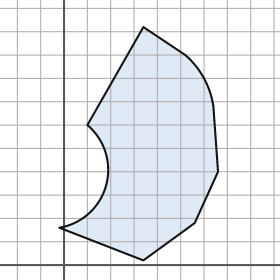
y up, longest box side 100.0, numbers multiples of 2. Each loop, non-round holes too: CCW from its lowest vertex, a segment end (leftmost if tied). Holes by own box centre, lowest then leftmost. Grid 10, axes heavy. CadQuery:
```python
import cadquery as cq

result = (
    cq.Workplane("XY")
    .moveTo(34.0, 2.0)
    .lineTo(56.0, 18.0)
    .lineTo(66.0, 40.0)
    .lineTo(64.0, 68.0)
    .threePointArc((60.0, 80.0), (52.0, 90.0))
    .lineTo(34.0, 102.0)
    .lineTo(10.0, 60.0)
    .threePointArc((18.0, 34.0), (-2.0, 16.0))
    .close()
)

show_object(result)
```